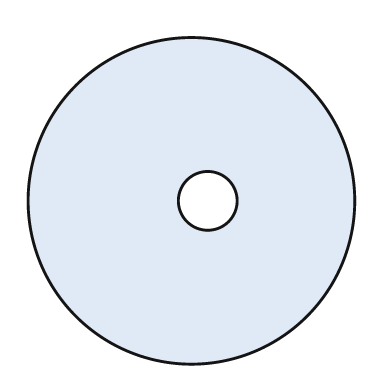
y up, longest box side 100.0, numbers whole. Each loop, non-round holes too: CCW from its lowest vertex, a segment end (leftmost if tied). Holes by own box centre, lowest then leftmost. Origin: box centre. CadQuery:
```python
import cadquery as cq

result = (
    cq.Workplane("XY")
    .moveTo(0.0, 0.0)
    .circle(50.0)
    .moveTo(5.0, 0.0)
    .circle(9.0)
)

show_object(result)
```